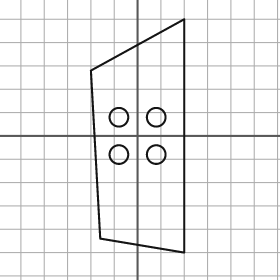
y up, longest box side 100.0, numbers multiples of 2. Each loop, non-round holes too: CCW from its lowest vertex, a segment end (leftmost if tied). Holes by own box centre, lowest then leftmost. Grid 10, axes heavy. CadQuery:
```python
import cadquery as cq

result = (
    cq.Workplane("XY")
    .moveTo(20.0, -50.0)
    .lineTo(20.0, 50.0)
    .lineTo(-20.0, 28.0)
    .lineTo(-16.0, -44.0)
    .close()
    .moveTo(-8.0, -8.0)
    .circle(4.0)
    .moveTo(8.0, -8.0)
    .circle(4.0)
    .moveTo(-8.0, 8.0)
    .circle(4.0)
    .moveTo(8.0, 8.0)
    .circle(4.0)
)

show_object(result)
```